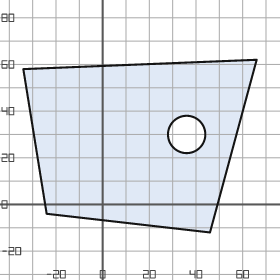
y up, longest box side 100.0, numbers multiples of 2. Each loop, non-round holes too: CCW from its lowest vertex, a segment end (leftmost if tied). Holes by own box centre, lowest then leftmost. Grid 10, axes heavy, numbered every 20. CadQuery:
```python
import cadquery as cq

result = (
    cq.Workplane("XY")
    .moveTo(46.0, -12.0)
    .lineTo(66.0, 62.0)
    .lineTo(-34.0, 58.0)
    .lineTo(-24.0, -4.0)
    .close()
    .moveTo(36.0, 30.0)
    .circle(8.0)
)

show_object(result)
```